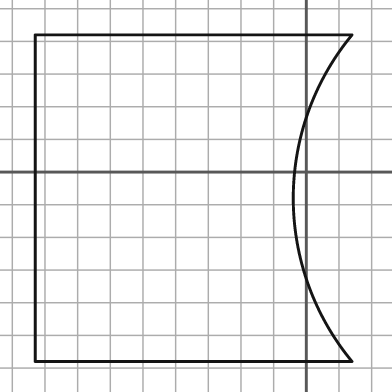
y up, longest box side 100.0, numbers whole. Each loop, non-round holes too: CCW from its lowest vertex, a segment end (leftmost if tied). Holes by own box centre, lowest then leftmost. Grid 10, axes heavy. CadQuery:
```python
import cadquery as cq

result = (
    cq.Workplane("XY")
    .moveTo(-83.0, -58.0)
    .lineTo(14.0, -58.0)
    .threePointArc((-4.0, -8.0), (14.0, 42.0))
    .lineTo(-83.0, 42.0)
    .close()
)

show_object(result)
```